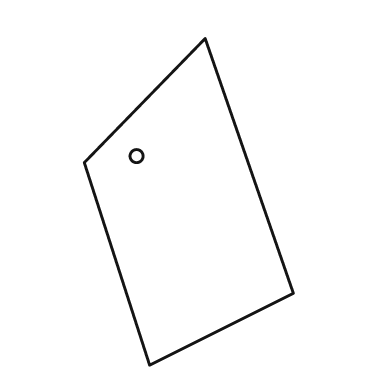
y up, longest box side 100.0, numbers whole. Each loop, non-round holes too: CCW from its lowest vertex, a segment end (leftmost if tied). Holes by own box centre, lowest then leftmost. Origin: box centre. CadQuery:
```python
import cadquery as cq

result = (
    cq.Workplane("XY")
    .moveTo(-12.0, -50.0)
    .lineTo(32.0, -28.0)
    .lineTo(5.0, 50.0)
    .lineTo(-32.0, 12.0)
    .close()
    .moveTo(-16.0, 14.0)
    .circle(2.0)
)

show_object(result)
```